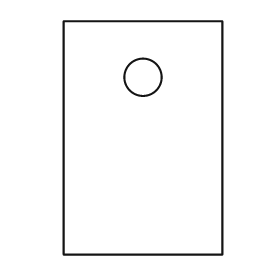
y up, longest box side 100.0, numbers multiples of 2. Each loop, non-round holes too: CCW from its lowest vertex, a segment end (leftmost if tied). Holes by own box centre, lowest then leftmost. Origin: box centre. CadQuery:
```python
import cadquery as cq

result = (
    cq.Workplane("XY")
    .moveTo(-34.0, -50.0)
    .lineTo(34.0, -50.0)
    .lineTo(34.0, 50.0)
    .lineTo(-34.0, 50.0)
    .close()
    .moveTo(0.0, 26.0)
    .circle(8.0)
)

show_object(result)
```